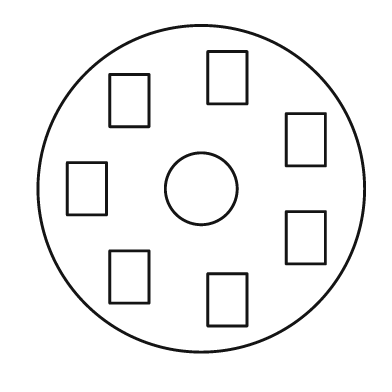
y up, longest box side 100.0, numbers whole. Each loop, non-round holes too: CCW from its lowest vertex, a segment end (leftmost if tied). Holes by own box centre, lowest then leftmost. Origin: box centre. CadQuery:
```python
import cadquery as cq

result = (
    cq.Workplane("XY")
    .moveTo(0.0, 0.0)
    .circle(50.0)
    .moveTo(2.0, -42.0)
    .lineTo(14.0, -42.0)
    .lineTo(14.0, -26.0)
    .lineTo(2.0, -26.0)
    .close()
    .moveTo(-28.0, -35.0)
    .lineTo(-16.0, -35.0)
    .lineTo(-16.0, -19.0)
    .lineTo(-28.0, -19.0)
    .close()
    .moveTo(26.0, -23.0)
    .lineTo(38.0, -23.0)
    .lineTo(38.0, -7.0)
    .lineTo(26.0, -7.0)
    .close()
    .moveTo(-41.0, -8.0)
    .lineTo(-29.0, -8.0)
    .lineTo(-29.0, 8.0)
    .lineTo(-41.0, 8.0)
    .close()
    .moveTo(0.0, 0.0)
    .circle(11.0)
    .moveTo(26.0, 7.0)
    .lineTo(38.0, 7.0)
    .lineTo(38.0, 23.0)
    .lineTo(26.0, 23.0)
    .close()
    .moveTo(-28.0, 19.0)
    .lineTo(-16.0, 19.0)
    .lineTo(-16.0, 35.0)
    .lineTo(-28.0, 35.0)
    .close()
    .moveTo(2.0, 26.0)
    .lineTo(14.0, 26.0)
    .lineTo(14.0, 42.0)
    .lineTo(2.0, 42.0)
    .close()
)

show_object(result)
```